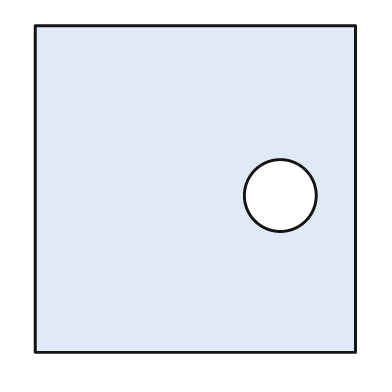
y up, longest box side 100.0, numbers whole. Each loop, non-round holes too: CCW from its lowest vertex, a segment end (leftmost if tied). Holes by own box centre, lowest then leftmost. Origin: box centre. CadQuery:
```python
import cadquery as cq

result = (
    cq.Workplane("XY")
    .moveTo(-49.0, -50.0)
    .lineTo(49.0, -50.0)
    .lineTo(49.0, 50.0)
    .lineTo(-49.0, 50.0)
    .close()
    .moveTo(26.0, -2.0)
    .circle(11.0)
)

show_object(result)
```